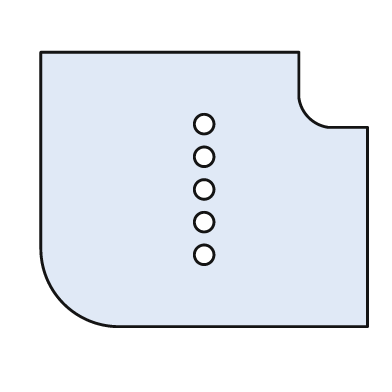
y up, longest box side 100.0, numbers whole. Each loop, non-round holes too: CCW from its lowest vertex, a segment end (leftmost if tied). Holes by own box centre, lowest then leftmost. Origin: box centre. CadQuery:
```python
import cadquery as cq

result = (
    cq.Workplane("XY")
    .moveTo(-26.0, -42.0)
    .lineTo(50.0, -42.0)
    .lineTo(50.0, 19.0)
    .lineTo(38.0, 19.0)
    .threePointArc((32.0, 22.0), (29.0, 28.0))
    .lineTo(29.0, 42.0)
    .lineTo(-50.0, 42.0)
    .lineTo(-50.0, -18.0)
    .threePointArc((-43.0, -35.0), (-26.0, -42.0))
    .close()
    .moveTo(0.0, -20.0)
    .circle(3.0)
    .moveTo(0.0, -10.0)
    .circle(3.0)
    .moveTo(0.0, 0.0)
    .circle(3.0)
    .moveTo(0.0, 10.0)
    .circle(3.0)
    .moveTo(0.0, 20.0)
    .circle(3.0)
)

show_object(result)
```